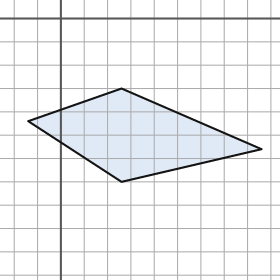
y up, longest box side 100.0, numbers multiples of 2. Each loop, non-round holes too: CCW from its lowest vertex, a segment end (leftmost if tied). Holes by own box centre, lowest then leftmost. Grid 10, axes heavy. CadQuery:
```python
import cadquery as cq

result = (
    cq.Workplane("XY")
    .moveTo(26.0, -70.0)
    .lineTo(86.0, -56.0)
    .lineTo(26.0, -30.0)
    .lineTo(-14.0, -44.0)
    .close()
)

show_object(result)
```